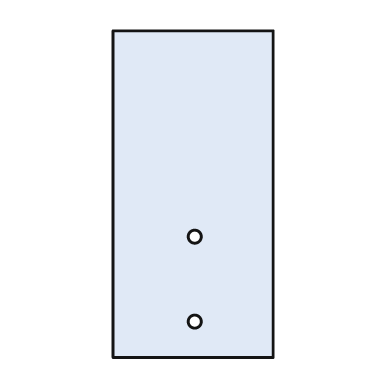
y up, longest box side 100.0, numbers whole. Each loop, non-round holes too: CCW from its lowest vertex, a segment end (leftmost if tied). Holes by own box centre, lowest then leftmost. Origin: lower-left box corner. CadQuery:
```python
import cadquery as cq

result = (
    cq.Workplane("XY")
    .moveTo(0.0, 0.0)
    .lineTo(49.0, 0.0)
    .lineTo(49.0, 100.0)
    .lineTo(0.0, 100.0)
    .close()
    .moveTo(25.0, 11.0)
    .circle(2.0)
    .moveTo(25.0, 37.0)
    .circle(2.0)
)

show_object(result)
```